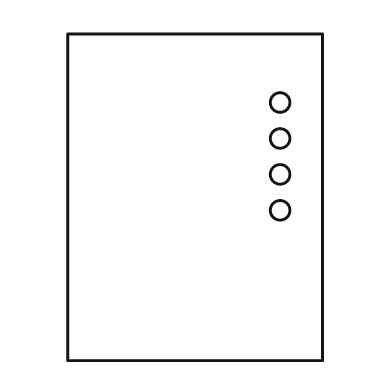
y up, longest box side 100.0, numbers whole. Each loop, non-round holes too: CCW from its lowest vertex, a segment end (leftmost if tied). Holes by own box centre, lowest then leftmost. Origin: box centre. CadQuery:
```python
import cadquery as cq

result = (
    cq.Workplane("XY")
    .moveTo(-39.0, -50.0)
    .lineTo(39.0, -50.0)
    .lineTo(39.0, 50.0)
    .lineTo(-39.0, 50.0)
    .close()
    .moveTo(26.0, -4.0)
    .circle(3.0)
    .moveTo(26.0, 7.0)
    .circle(3.0)
    .moveTo(26.0, 18.0)
    .circle(3.0)
    .moveTo(26.0, 29.0)
    .circle(3.0)
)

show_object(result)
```